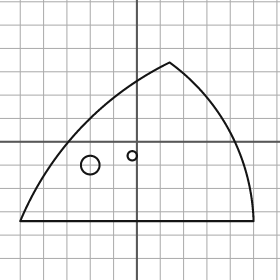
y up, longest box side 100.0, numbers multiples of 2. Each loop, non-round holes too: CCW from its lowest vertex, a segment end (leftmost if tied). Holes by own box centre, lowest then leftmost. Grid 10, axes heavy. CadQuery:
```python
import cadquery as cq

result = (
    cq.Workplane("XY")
    .moveTo(-50.0, -34.0)
    .lineTo(50.0, -34.0)
    .threePointArc((40.0, 4.0), (14.0, 34.0))
    .threePointArc((-24.0, 6.0), (-50.0, -34.0))
    .close()
    .moveTo(-20.0, -10.0)
    .circle(4.0)
    .moveTo(-2.0, -6.0)
    .circle(2.0)
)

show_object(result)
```